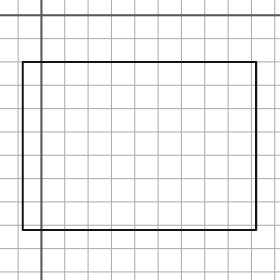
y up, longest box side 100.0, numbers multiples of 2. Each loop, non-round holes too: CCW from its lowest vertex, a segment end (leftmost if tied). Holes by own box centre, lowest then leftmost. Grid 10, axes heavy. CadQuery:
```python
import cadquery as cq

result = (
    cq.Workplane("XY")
    .moveTo(-8.0, -92.0)
    .lineTo(92.0, -92.0)
    .lineTo(92.0, -20.0)
    .lineTo(-8.0, -20.0)
    .close()
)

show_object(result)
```